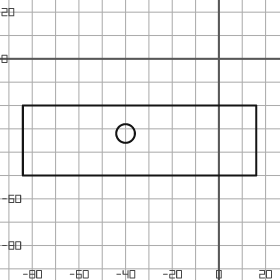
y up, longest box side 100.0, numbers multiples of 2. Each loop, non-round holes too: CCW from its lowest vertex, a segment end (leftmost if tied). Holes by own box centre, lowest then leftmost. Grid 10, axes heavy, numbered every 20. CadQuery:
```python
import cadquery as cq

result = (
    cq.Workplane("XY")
    .moveTo(-84.0, -50.0)
    .lineTo(16.0, -50.0)
    .lineTo(16.0, -20.0)
    .lineTo(-84.0, -20.0)
    .close()
    .moveTo(-40.0, -32.0)
    .circle(4.0)
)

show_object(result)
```